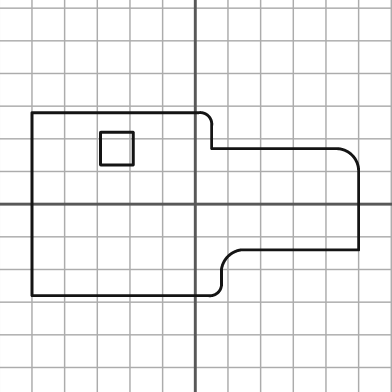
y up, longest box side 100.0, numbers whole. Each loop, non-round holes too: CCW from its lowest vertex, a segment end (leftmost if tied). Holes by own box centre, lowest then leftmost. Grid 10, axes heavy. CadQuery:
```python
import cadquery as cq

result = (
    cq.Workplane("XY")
    .moveTo(-50.0, -28.0)
    .lineTo(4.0, -28.0)
    .threePointArc((7.0, -27.0), (8.0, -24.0))
    .lineTo(8.0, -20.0)
    .threePointArc((10.0, -16.0), (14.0, -14.0))
    .lineTo(50.0, -14.0)
    .lineTo(50.0, 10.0)
    .threePointArc((48.0, 15.0), (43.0, 17.0))
    .lineTo(5.0, 17.0)
    .lineTo(5.0, 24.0)
    .threePointArc((4.0, 27.0), (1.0, 28.0))
    .lineTo(-50.0, 28.0)
    .close()
    .moveTo(-29.0, 12.0)
    .lineTo(-19.0, 12.0)
    .lineTo(-19.0, 22.0)
    .lineTo(-29.0, 22.0)
    .close()
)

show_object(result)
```